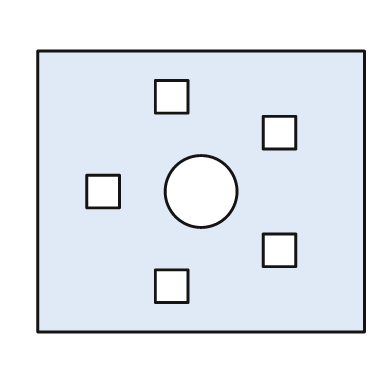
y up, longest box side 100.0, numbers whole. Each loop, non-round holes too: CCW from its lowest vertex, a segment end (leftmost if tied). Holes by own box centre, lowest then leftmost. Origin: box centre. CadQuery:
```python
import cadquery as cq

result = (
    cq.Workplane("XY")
    .moveTo(-50.0, -43.0)
    .lineTo(50.0, -43.0)
    .lineTo(50.0, 43.0)
    .lineTo(-50.0, 43.0)
    .close()
    .moveTo(-14.0, -34.0)
    .lineTo(-4.0, -34.0)
    .lineTo(-4.0, -24.0)
    .lineTo(-14.0, -24.0)
    .close()
    .moveTo(19.0, -23.0)
    .lineTo(29.0, -23.0)
    .lineTo(29.0, -13.0)
    .lineTo(19.0, -13.0)
    .close()
    .moveTo(-35.0, -5.0)
    .lineTo(-25.0, -5.0)
    .lineTo(-25.0, 5.0)
    .lineTo(-35.0, 5.0)
    .close()
    .moveTo(0.0, 0.0)
    .circle(11.0)
    .moveTo(19.0, 13.0)
    .lineTo(29.0, 13.0)
    .lineTo(29.0, 23.0)
    .lineTo(19.0, 23.0)
    .close()
    .moveTo(-14.0, 24.0)
    .lineTo(-4.0, 24.0)
    .lineTo(-4.0, 34.0)
    .lineTo(-14.0, 34.0)
    .close()
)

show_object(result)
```